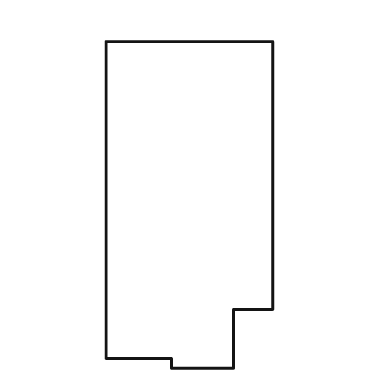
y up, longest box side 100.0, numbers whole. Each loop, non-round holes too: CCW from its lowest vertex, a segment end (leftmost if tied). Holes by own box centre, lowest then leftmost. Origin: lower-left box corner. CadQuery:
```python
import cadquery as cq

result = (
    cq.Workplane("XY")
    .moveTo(20.0, 0.0)
    .lineTo(39.0, 0.0)
    .lineTo(39.0, 18.0)
    .lineTo(51.0, 18.0)
    .lineTo(51.0, 100.0)
    .lineTo(0.0, 100.0)
    .lineTo(0.0, 3.0)
    .lineTo(20.0, 3.0)
    .close()
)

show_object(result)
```